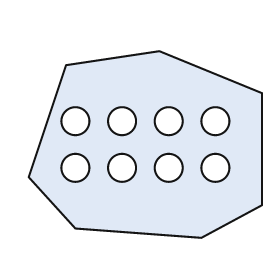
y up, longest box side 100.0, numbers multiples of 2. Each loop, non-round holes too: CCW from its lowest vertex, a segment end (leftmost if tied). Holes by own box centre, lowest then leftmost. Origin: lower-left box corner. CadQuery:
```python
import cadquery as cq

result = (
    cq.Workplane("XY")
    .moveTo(74.0, 0.0)
    .lineTo(100.0, 14.0)
    .lineTo(100.0, 62.0)
    .lineTo(56.0, 80.0)
    .lineTo(16.0, 74.0)
    .lineTo(0.0, 26.0)
    .lineTo(20.0, 4.0)
    .close()
    .moveTo(20.0, 30.0)
    .circle(6.0)
    .moveTo(40.0, 30.0)
    .circle(6.0)
    .moveTo(60.0, 30.0)
    .circle(6.0)
    .moveTo(80.0, 30.0)
    .circle(6.0)
    .moveTo(20.0, 50.0)
    .circle(6.0)
    .moveTo(40.0, 50.0)
    .circle(6.0)
    .moveTo(60.0, 50.0)
    .circle(6.0)
    .moveTo(80.0, 50.0)
    .circle(6.0)
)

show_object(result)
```